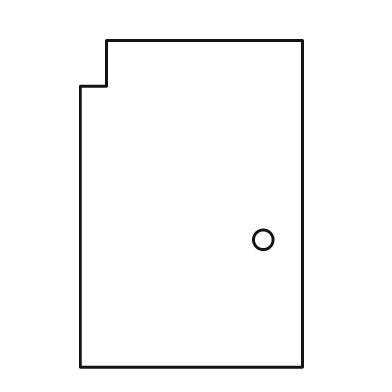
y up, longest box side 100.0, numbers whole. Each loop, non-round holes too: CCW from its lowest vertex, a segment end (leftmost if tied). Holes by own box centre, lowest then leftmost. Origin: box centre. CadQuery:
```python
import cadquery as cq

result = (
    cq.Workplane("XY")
    .moveTo(-34.0, -50.0)
    .lineTo(34.0, -50.0)
    .lineTo(34.0, 50.0)
    .lineTo(-26.0, 50.0)
    .lineTo(-26.0, 36.0)
    .lineTo(-34.0, 36.0)
    .close()
    .moveTo(22.0, -11.0)
    .circle(3.0)
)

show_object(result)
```